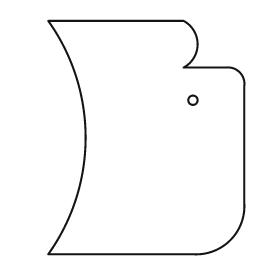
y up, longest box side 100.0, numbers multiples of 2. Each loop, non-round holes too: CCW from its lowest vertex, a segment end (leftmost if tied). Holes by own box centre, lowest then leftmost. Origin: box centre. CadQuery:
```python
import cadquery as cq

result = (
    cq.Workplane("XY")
    .moveTo(-42.0, -50.0)
    .lineTo(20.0, -50.0)
    .threePointArc((36.0, -44.0), (42.0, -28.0))
    .lineTo(42.0, 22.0)
    .threePointArc((40.0, 28.0), (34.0, 30.0))
    .lineTo(16.0, 30.0)
    .threePointArc((22.0, 40.0), (16.0, 50.0))
    .lineTo(-42.0, 50.0)
    .threePointArc((-26.0, 0.0), (-42.0, -50.0))
    .close()
    .moveTo(20.0, 16.0)
    .circle(2.0)
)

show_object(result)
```